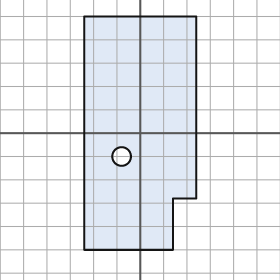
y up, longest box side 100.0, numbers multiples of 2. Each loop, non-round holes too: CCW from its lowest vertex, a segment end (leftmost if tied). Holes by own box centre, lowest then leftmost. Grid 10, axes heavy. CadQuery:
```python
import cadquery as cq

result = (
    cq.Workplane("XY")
    .moveTo(-24.0, -50.0)
    .lineTo(14.0, -50.0)
    .lineTo(14.0, -28.0)
    .lineTo(24.0, -28.0)
    .lineTo(24.0, 50.0)
    .lineTo(-24.0, 50.0)
    .close()
    .moveTo(-8.0, -10.0)
    .circle(4.0)
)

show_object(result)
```